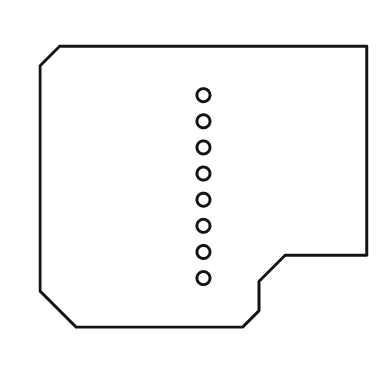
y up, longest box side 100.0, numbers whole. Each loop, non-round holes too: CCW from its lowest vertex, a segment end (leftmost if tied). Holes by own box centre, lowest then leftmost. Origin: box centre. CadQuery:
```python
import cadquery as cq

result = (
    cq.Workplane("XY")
    .moveTo(-39.0, -43.0)
    .lineTo(12.0, -43.0)
    .lineTo(17.0, -38.0)
    .lineTo(17.0, -29.0)
    .lineTo(25.0, -21.0)
    .lineTo(50.0, -21.0)
    .lineTo(50.0, 43.0)
    .lineTo(-44.0, 43.0)
    .lineTo(-50.0, 37.0)
    .lineTo(-50.0, -32.0)
    .close()
    .moveTo(0.0, -28.0)
    .circle(2.0)
    .moveTo(0.0, -20.0)
    .circle(2.0)
    .moveTo(0.0, -12.0)
    .circle(2.0)
    .moveTo(0.0, -4.0)
    .circle(2.0)
    .moveTo(0.0, 4.0)
    .circle(2.0)
    .moveTo(0.0, 12.0)
    .circle(2.0)
    .moveTo(0.0, 20.0)
    .circle(2.0)
    .moveTo(0.0, 28.0)
    .circle(2.0)
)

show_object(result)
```